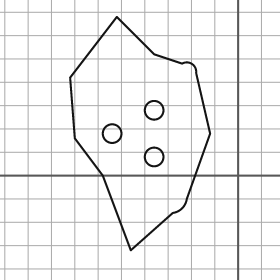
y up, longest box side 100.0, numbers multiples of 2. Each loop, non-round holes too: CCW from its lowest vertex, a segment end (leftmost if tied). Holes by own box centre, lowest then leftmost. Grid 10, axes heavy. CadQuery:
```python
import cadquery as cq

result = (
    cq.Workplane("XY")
    .moveTo(-46.0, -32.0)
    .lineTo(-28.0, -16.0)
    .threePointArc((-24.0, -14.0), (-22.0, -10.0))
    .lineTo(-12.0, 18.0)
    .lineTo(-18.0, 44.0)
    .threePointArc((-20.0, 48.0), (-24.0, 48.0))
    .lineTo(-36.0, 52.0)
    .lineTo(-52.0, 68.0)
    .lineTo(-72.0, 42.0)
    .lineTo(-70.0, 16.0)
    .lineTo(-58.0, 0.0)
    .close()
    .moveTo(-36.0, 8.0)
    .circle(4.0)
    .moveTo(-54.0, 18.0)
    .circle(4.0)
    .moveTo(-36.0, 28.0)
    .circle(4.0)
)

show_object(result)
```